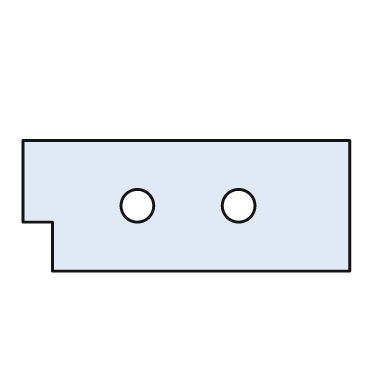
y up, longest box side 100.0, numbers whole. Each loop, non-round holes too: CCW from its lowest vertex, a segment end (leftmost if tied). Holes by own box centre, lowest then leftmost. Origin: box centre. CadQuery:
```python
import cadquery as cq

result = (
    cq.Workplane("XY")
    .moveTo(-41.0, -20.0)
    .lineTo(50.0, -20.0)
    .lineTo(50.0, 20.0)
    .lineTo(-50.0, 20.0)
    .lineTo(-50.0, -5.0)
    .lineTo(-41.0, -5.0)
    .close()
    .moveTo(-15.0, 0.0)
    .circle(5.0)
    .moveTo(16.0, 0.0)
    .circle(5.0)
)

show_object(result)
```